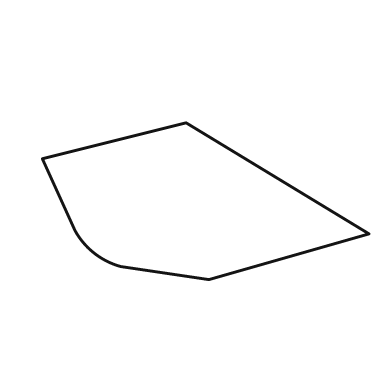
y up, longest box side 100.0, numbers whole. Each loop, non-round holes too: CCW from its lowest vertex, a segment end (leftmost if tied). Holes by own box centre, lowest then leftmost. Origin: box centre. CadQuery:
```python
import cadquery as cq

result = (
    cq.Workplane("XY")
    .moveTo(1.0, -24.0)
    .lineTo(50.0, -10.0)
    .lineTo(-6.0, 24.0)
    .lineTo(-50.0, 13.0)
    .lineTo(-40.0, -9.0)
    .threePointArc((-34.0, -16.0), (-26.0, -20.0))
    .close()
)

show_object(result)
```